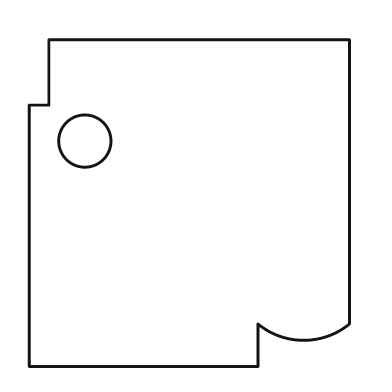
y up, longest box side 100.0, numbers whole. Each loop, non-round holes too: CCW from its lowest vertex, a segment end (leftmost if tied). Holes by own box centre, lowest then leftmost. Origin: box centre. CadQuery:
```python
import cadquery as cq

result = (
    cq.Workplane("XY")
    .moveTo(-49.0, -50.0)
    .lineTo(21.0, -50.0)
    .lineTo(21.0, -37.0)
    .threePointArc((35.0, -42.0), (49.0, -37.0))
    .lineTo(49.0, 50.0)
    .lineTo(-43.0, 50.0)
    .lineTo(-43.0, 30.0)
    .lineTo(-49.0, 30.0)
    .close()
    .moveTo(-32.0, 19.0)
    .circle(8.0)
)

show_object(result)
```